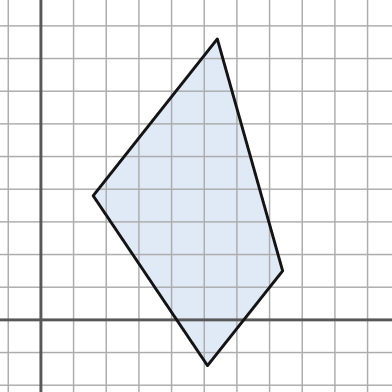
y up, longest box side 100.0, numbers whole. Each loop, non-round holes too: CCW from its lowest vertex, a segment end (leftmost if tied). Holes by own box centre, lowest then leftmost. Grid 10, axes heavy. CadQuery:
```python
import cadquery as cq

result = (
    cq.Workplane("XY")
    .moveTo(51.0, -14.0)
    .lineTo(74.0, 15.0)
    .lineTo(54.0, 86.0)
    .lineTo(16.0, 38.0)
    .close()
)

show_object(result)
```